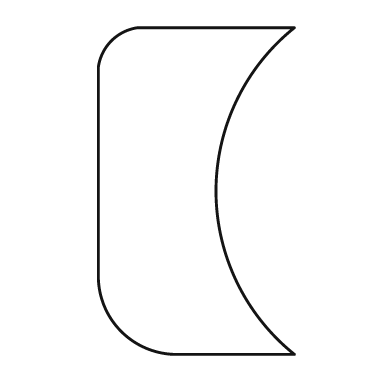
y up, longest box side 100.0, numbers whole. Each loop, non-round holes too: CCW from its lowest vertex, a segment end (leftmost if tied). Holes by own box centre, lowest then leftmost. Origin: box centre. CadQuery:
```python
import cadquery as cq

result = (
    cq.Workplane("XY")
    .moveTo(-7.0, -50.0)
    .lineTo(30.0, -50.0)
    .threePointArc((6.0, 0.0), (30.0, 50.0))
    .lineTo(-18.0, 50.0)
    .threePointArc((-26.0, 46.0), (-30.0, 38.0))
    .lineTo(-30.0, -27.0)
    .threePointArc((-23.0, -43.0), (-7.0, -50.0))
    .close()
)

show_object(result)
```